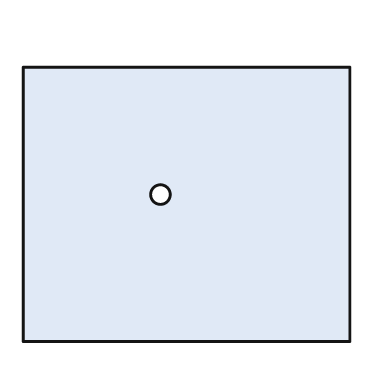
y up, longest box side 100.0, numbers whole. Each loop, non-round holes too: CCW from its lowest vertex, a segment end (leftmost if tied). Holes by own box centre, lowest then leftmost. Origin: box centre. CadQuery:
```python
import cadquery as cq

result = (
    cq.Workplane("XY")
    .moveTo(-50.0, -42.0)
    .lineTo(50.0, -42.0)
    .lineTo(50.0, 42.0)
    .lineTo(-50.0, 42.0)
    .close()
    .moveTo(-8.0, 3.0)
    .circle(3.0)
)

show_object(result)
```